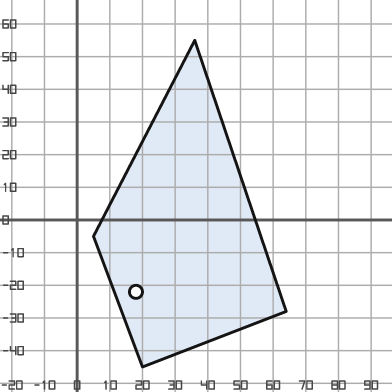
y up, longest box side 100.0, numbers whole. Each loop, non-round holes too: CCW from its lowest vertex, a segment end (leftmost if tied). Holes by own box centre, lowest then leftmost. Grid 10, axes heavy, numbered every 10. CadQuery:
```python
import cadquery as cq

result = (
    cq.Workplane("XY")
    .moveTo(20.0, -45.0)
    .lineTo(64.0, -28.0)
    .lineTo(36.0, 55.0)
    .lineTo(5.0, -5.0)
    .close()
    .moveTo(18.0, -22.0)
    .circle(2.0)
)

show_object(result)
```